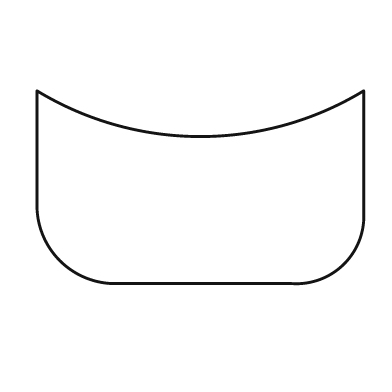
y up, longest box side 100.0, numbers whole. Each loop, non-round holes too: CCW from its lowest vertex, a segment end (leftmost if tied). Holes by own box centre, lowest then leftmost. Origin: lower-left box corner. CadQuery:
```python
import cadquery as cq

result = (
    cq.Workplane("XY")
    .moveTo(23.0, 0.0)
    .lineTo(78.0, 0.0)
    .threePointArc((94.0, 6.0), (100.0, 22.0))
    .lineTo(100.0, 59.0)
    .threePointArc((50.0, 45.0), (0.0, 59.0))
    .lineTo(0.0, 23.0)
    .threePointArc((7.0, 7.0), (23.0, 0.0))
    .close()
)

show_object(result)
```